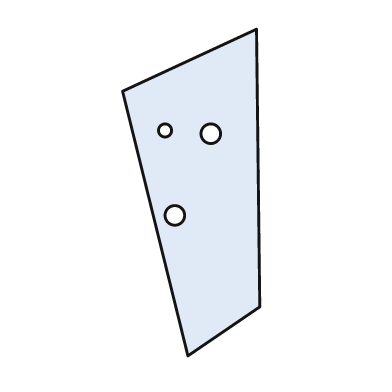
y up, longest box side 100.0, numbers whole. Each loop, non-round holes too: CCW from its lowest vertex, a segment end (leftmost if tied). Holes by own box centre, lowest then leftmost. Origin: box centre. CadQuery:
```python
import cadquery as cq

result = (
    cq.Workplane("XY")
    .moveTo(-1.0, -50.0)
    .lineTo(21.0, -35.0)
    .lineTo(20.0, 50.0)
    .lineTo(-21.0, 31.0)
    .close()
    .moveTo(-5.0, -7.0)
    .circle(3.0)
    .moveTo(6.0, 18.0)
    .circle(3.0)
    .moveTo(-8.0, 19.0)
    .circle(2.0)
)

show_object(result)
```